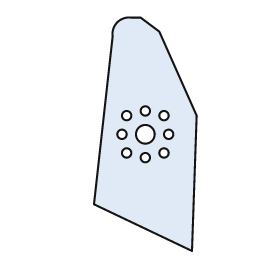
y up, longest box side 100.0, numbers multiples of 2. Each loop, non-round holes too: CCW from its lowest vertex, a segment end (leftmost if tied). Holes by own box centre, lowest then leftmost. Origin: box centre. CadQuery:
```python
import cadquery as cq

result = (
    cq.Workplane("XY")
    .moveTo(20.0, -50.0)
    .lineTo(22.0, 8.0)
    .lineTo(6.0, 44.0)
    .lineTo(-2.0, 50.0)
    .lineTo(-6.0, 50.0)
    .threePointArc((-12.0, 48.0), (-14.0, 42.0))
    .lineTo(-22.0, -30.0)
    .close()
    .moveTo(0.0, -10.0)
    .circle(2.0)
    .moveTo(-8.0, -8.0)
    .circle(2.0)
    .moveTo(8.0, -8.0)
    .circle(2.0)
    .moveTo(-10.0, 0.0)
    .circle(2.0)
    .moveTo(0.0, 0.0)
    .circle(4.0)
    .moveTo(10.0, 0.0)
    .circle(2.0)
    .moveTo(-8.0, 8.0)
    .circle(2.0)
    .moveTo(8.0, 8.0)
    .circle(2.0)
    .moveTo(0.0, 10.0)
    .circle(2.0)
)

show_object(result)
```